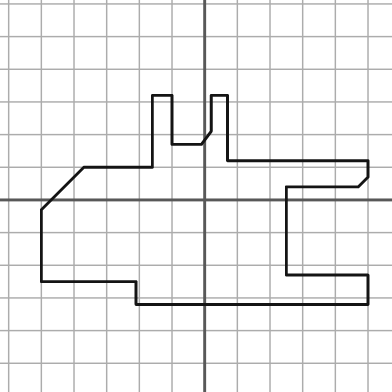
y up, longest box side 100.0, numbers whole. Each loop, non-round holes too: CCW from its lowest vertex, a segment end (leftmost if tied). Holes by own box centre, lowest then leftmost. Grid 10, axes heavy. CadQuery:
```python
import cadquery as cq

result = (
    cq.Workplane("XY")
    .moveTo(-21.0, -32.0)
    .lineTo(50.0, -32.0)
    .lineTo(50.0, -23.0)
    .lineTo(25.0, -23.0)
    .lineTo(25.0, 4.0)
    .lineTo(47.0, 4.0)
    .lineTo(50.0, 7.0)
    .lineTo(50.0, 12.0)
    .lineTo(7.0, 12.0)
    .lineTo(7.0, 32.0)
    .lineTo(2.0, 32.0)
    .lineTo(2.0, 21.0)
    .lineTo(-1.0, 17.0)
    .lineTo(-10.0, 17.0)
    .lineTo(-10.0, 32.0)
    .lineTo(-16.0, 32.0)
    .lineTo(-16.0, 10.0)
    .lineTo(-37.0, 10.0)
    .lineTo(-50.0, -3.0)
    .lineTo(-50.0, -25.0)
    .lineTo(-21.0, -25.0)
    .close()
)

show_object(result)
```